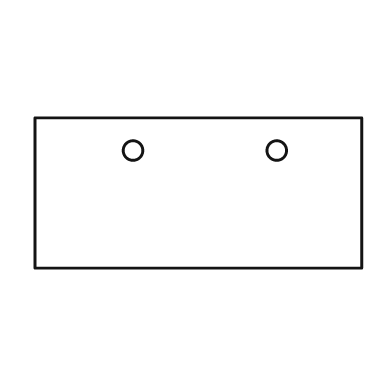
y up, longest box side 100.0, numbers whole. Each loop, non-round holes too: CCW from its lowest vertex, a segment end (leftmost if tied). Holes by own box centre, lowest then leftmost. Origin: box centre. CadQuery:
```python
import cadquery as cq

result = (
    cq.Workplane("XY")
    .moveTo(-50.0, -23.0)
    .lineTo(50.0, -23.0)
    .lineTo(50.0, 23.0)
    .lineTo(-50.0, 23.0)
    .close()
    .moveTo(-20.0, 13.0)
    .circle(3.0)
    .moveTo(24.0, 13.0)
    .circle(3.0)
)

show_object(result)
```